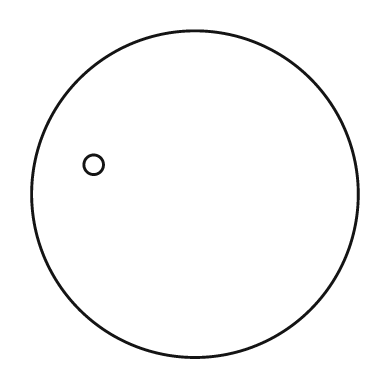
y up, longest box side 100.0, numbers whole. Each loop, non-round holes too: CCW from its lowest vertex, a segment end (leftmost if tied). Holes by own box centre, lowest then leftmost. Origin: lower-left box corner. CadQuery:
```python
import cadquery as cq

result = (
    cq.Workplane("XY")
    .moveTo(50.0, 50.0)
    .circle(50.0)
    .moveTo(19.0, 59.0)
    .circle(3.0)
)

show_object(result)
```